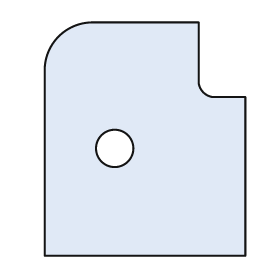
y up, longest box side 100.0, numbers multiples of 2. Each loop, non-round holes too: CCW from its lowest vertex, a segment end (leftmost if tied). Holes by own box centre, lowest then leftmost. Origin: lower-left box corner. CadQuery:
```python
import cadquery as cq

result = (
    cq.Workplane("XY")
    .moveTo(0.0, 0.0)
    .lineTo(86.0, 0.0)
    .lineTo(86.0, 68.0)
    .lineTo(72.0, 68.0)
    .threePointArc((68.0, 70.0), (66.0, 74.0))
    .lineTo(66.0, 100.0)
    .lineTo(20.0, 100.0)
    .threePointArc((6.0, 94.0), (0.0, 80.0))
    .close()
    .moveTo(30.0, 46.0)
    .circle(8.0)
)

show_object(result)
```